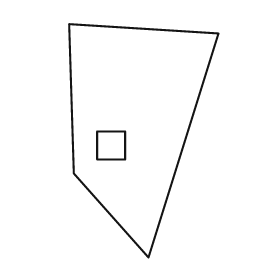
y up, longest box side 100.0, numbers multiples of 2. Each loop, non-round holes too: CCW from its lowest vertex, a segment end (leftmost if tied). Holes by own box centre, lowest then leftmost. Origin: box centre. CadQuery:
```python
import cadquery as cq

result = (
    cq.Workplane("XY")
    .moveTo(2.0, -50.0)
    .lineTo(32.0, 46.0)
    .lineTo(-32.0, 50.0)
    .lineTo(-30.0, -14.0)
    .close()
    .moveTo(-20.0, -8.0)
    .lineTo(-8.0, -8.0)
    .lineTo(-8.0, 4.0)
    .lineTo(-20.0, 4.0)
    .close()
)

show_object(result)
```